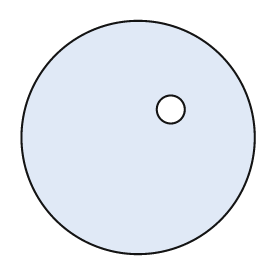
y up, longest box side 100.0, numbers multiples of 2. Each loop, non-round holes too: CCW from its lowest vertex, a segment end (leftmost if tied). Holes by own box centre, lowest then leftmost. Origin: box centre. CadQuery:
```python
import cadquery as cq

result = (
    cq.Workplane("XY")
    .moveTo(0.0, 0.0)
    .circle(50.0)
    .moveTo(14.0, 12.0)
    .circle(6.0)
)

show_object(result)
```